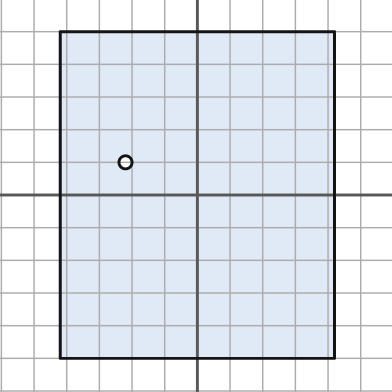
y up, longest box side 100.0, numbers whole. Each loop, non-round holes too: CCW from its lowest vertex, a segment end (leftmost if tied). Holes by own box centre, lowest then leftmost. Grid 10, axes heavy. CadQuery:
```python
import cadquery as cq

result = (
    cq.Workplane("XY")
    .moveTo(-42.0, -50.0)
    .lineTo(42.0, -50.0)
    .lineTo(42.0, 50.0)
    .lineTo(-42.0, 50.0)
    .close()
    .moveTo(-22.0, 10.0)
    .circle(2.0)
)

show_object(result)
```